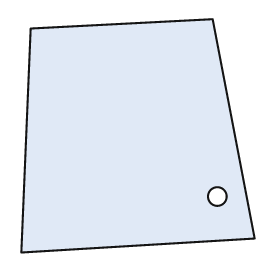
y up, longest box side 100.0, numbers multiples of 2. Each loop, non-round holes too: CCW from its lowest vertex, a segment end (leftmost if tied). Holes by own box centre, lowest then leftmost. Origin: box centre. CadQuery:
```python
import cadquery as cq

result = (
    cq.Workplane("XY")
    .moveTo(-50.0, -50.0)
    .lineTo(50.0, -44.0)
    .lineTo(32.0, 50.0)
    .lineTo(-46.0, 46.0)
    .close()
    .moveTo(34.0, -26.0)
    .circle(4.0)
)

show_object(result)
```